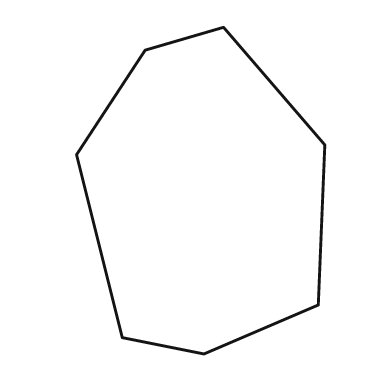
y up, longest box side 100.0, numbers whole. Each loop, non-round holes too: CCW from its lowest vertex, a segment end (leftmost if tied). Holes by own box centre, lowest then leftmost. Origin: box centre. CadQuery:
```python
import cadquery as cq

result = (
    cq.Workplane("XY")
    .moveTo(1.0, -50.0)
    .lineTo(36.0, -35.0)
    .lineTo(38.0, 14.0)
    .lineTo(7.0, 50.0)
    .lineTo(-17.0, 43.0)
    .lineTo(-38.0, 11.0)
    .lineTo(-24.0, -45.0)
    .close()
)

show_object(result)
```